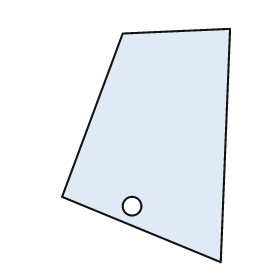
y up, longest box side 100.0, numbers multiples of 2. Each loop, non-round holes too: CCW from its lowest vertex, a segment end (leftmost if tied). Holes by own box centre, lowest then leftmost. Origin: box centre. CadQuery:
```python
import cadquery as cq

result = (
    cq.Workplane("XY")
    .moveTo(32.0, -50.0)
    .lineTo(36.0, 50.0)
    .lineTo(-10.0, 48.0)
    .lineTo(-36.0, -22.0)
    .close()
    .moveTo(-6.0, -26.0)
    .circle(4.0)
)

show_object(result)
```